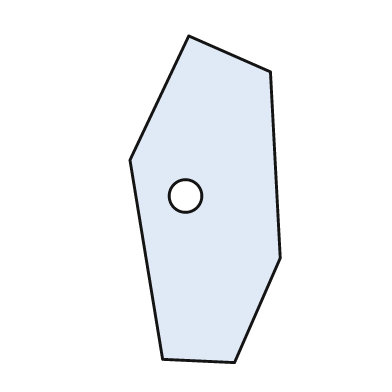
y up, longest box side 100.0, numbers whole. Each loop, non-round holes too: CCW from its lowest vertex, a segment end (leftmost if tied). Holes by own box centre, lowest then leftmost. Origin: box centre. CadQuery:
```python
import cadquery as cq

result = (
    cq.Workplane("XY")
    .moveTo(9.0, -50.0)
    .lineTo(23.0, -18.0)
    .lineTo(20.0, 39.0)
    .lineTo(-5.0, 50.0)
    .lineTo(-23.0, 12.0)
    .lineTo(-13.0, -49.0)
    .close()
    .moveTo(-6.0, 1.0)
    .circle(5.0)
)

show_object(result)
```